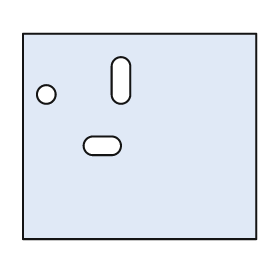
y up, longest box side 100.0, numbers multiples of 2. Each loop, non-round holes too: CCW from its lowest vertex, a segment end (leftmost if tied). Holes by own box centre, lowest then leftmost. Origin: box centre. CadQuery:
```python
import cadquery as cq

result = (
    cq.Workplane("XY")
    .moveTo(-50.0, -44.0)
    .lineTo(50.0, -44.0)
    .lineTo(50.0, 44.0)
    .lineTo(-50.0, 44.0)
    .close()
    .moveTo(-20.0, -8.0)
    .lineTo(-12.0, -8.0)
    .threePointArc((-8.0, -4.0), (-12.0, 0.0))
    .lineTo(-20.0, 0.0)
    .threePointArc((-24.0, -4.0), (-20.0, -8.0))
    .close()
    .moveTo(-40.0, 18.0)
    .circle(4.0)
    .moveTo(-12.0, 18.0)
    .threePointArc((-8.0, 14.0), (-4.0, 18.0))
    .lineTo(-4.0, 30.0)
    .threePointArc((-8.0, 34.0), (-12.0, 30.0))
    .close()
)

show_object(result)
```